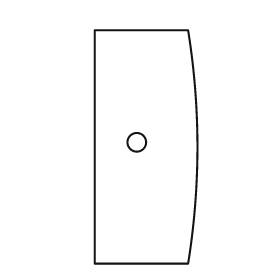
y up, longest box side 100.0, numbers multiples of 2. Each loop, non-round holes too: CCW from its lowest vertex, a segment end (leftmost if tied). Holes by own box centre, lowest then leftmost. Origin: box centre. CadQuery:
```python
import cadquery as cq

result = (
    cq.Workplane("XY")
    .moveTo(-22.0, -50.0)
    .lineTo(18.0, -50.0)
    .threePointArc((22.0, 0.0), (18.0, 50.0))
    .lineTo(-22.0, 50.0)
    .close()
    .moveTo(-4.0, 2.0)
    .circle(4.0)
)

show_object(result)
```